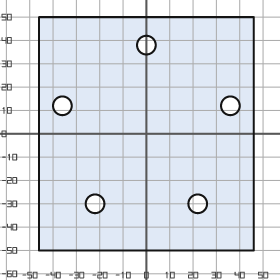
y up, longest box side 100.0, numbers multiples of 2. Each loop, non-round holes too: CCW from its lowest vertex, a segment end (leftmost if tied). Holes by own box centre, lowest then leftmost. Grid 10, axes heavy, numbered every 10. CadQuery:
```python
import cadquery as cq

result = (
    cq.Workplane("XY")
    .moveTo(-46.0, -50.0)
    .lineTo(46.0, -50.0)
    .lineTo(46.0, 50.0)
    .lineTo(-46.0, 50.0)
    .close()
    .moveTo(-22.0, -30.0)
    .circle(4.0)
    .moveTo(22.0, -30.0)
    .circle(4.0)
    .moveTo(-36.0, 12.0)
    .circle(4.0)
    .moveTo(36.0, 12.0)
    .circle(4.0)
    .moveTo(0.0, 38.0)
    .circle(4.0)
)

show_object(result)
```